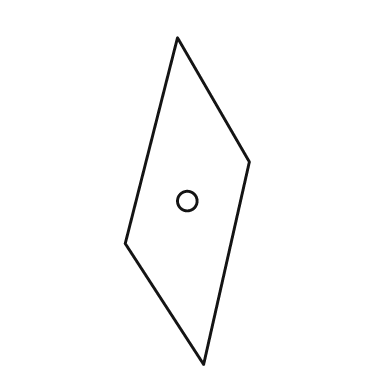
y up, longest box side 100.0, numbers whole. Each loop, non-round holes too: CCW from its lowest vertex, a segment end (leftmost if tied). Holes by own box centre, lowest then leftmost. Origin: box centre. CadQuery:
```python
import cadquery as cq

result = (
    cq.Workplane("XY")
    .moveTo(5.0, -50.0)
    .lineTo(19.0, 12.0)
    .lineTo(-3.0, 50.0)
    .lineTo(-19.0, -13.0)
    .close()
    .moveTo(0.0, 0.0)
    .circle(3.0)
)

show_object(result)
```